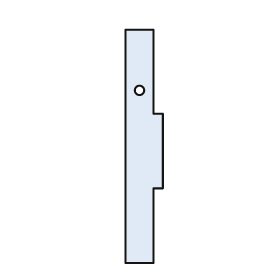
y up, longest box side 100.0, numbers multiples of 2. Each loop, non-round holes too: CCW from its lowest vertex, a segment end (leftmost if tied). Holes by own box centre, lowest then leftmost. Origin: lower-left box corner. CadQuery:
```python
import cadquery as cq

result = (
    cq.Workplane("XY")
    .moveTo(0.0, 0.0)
    .lineTo(12.0, 0.0)
    .lineTo(12.0, 32.0)
    .lineTo(16.0, 32.0)
    .lineTo(16.0, 64.0)
    .lineTo(12.0, 64.0)
    .lineTo(12.0, 100.0)
    .lineTo(0.0, 100.0)
    .close()
    .moveTo(6.0, 74.0)
    .circle(2.0)
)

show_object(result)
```